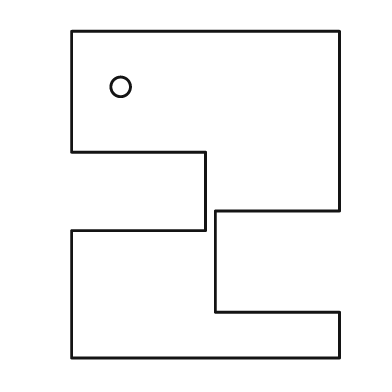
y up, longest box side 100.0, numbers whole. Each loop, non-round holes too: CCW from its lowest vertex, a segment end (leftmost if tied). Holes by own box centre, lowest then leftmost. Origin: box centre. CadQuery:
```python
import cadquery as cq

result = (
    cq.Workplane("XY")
    .moveTo(-41.0, -50.0)
    .lineTo(41.0, -50.0)
    .lineTo(41.0, -36.0)
    .lineTo(3.0, -36.0)
    .lineTo(3.0, -5.0)
    .lineTo(41.0, -5.0)
    .lineTo(41.0, 50.0)
    .lineTo(-41.0, 50.0)
    .lineTo(-41.0, 13.0)
    .lineTo(0.0, 13.0)
    .lineTo(0.0, -11.0)
    .lineTo(-41.0, -11.0)
    .close()
    .moveTo(-26.0, 33.0)
    .circle(3.0)
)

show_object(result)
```